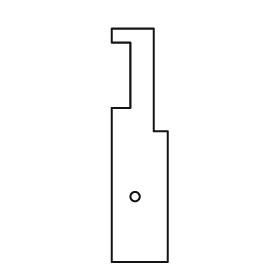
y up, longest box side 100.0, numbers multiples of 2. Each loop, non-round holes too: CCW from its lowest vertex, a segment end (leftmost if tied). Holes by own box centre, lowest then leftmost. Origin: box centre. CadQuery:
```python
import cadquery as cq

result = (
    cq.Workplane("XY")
    .moveTo(-12.0, -50.0)
    .lineTo(12.0, -50.0)
    .lineTo(12.0, 6.0)
    .lineTo(6.0, 6.0)
    .lineTo(6.0, 50.0)
    .lineTo(-12.0, 50.0)
    .lineTo(-12.0, 44.0)
    .lineTo(-4.0, 44.0)
    .lineTo(-4.0, 16.0)
    .lineTo(-12.0, 16.0)
    .close()
    .moveTo(-2.0, -22.0)
    .circle(2.0)
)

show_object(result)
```